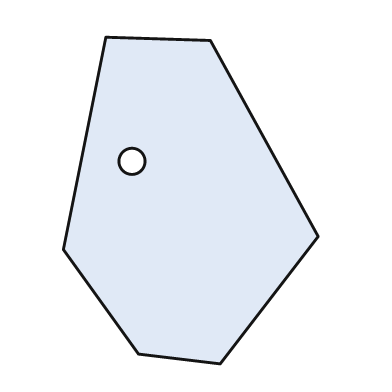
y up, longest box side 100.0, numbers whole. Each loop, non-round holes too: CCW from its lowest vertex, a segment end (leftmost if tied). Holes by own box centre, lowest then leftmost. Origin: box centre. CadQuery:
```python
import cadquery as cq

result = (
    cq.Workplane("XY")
    .moveTo(9.0, -50.0)
    .lineTo(39.0, -11.0)
    .lineTo(6.0, 49.0)
    .lineTo(-26.0, 50.0)
    .lineTo(-39.0, -15.0)
    .lineTo(-16.0, -47.0)
    .close()
    .moveTo(-18.0, 12.0)
    .circle(4.0)
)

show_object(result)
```